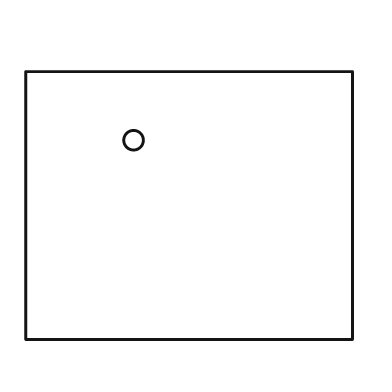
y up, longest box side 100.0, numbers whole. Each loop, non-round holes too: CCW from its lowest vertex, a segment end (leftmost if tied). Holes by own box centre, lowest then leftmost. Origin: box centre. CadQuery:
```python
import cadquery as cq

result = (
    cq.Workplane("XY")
    .moveTo(-50.0, -41.0)
    .lineTo(50.0, -41.0)
    .lineTo(50.0, 41.0)
    .lineTo(-50.0, 41.0)
    .close()
    .moveTo(-17.0, 20.0)
    .circle(3.0)
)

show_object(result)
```